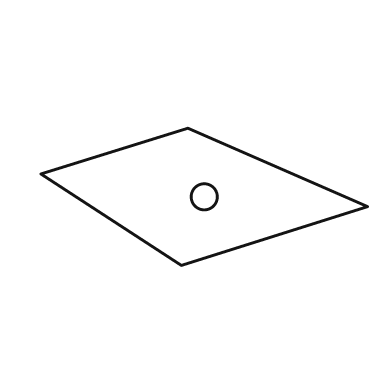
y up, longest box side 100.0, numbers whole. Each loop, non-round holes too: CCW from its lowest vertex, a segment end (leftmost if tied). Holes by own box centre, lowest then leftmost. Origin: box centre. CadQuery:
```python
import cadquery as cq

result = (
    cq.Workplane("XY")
    .moveTo(-7.0, -21.0)
    .lineTo(50.0, -3.0)
    .lineTo(-5.0, 21.0)
    .lineTo(-50.0, 7.0)
    .close()
    .moveTo(0.0, 0.0)
    .circle(4.0)
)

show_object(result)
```